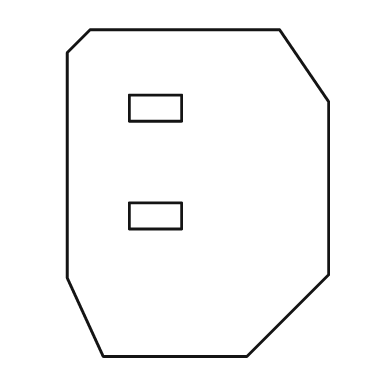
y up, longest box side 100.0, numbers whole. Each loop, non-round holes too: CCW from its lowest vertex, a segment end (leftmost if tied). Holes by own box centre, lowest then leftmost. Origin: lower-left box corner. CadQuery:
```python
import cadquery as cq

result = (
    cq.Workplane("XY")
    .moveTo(11.0, 0.0)
    .lineTo(55.0, 0.0)
    .lineTo(80.0, 25.0)
    .lineTo(80.0, 78.0)
    .lineTo(65.0, 100.0)
    .lineTo(7.0, 100.0)
    .lineTo(0.0, 93.0)
    .lineTo(0.0, 24.0)
    .close()
    .moveTo(19.0, 39.0)
    .lineTo(35.0, 39.0)
    .lineTo(35.0, 47.0)
    .lineTo(19.0, 47.0)
    .close()
    .moveTo(19.0, 72.0)
    .lineTo(35.0, 72.0)
    .lineTo(35.0, 80.0)
    .lineTo(19.0, 80.0)
    .close()
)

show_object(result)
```